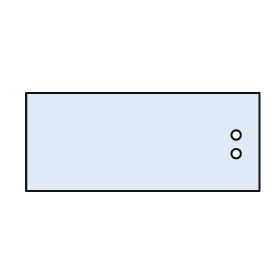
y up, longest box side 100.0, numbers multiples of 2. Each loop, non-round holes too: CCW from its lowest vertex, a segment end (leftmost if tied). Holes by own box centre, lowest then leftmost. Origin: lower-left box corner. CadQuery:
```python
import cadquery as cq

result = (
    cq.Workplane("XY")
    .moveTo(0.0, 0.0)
    .lineTo(100.0, 0.0)
    .lineTo(100.0, 42.0)
    .lineTo(0.0, 42.0)
    .close()
    .moveTo(90.0, 16.0)
    .circle(2.0)
    .moveTo(90.0, 24.0)
    .circle(2.0)
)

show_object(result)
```